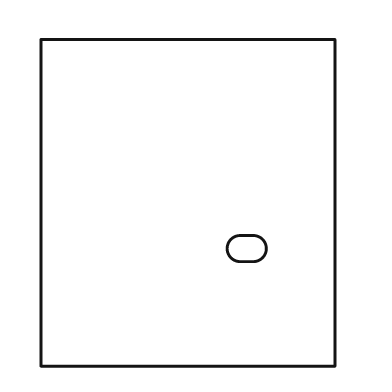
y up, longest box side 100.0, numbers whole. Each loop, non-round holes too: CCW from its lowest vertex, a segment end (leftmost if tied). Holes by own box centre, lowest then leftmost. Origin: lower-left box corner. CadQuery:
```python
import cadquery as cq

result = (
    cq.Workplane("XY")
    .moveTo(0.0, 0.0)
    .lineTo(90.0, 0.0)
    .lineTo(90.0, 100.0)
    .lineTo(0.0, 100.0)
    .close()
    .moveTo(61.0, 32.0)
    .lineTo(65.0, 32.0)
    .threePointArc((69.0, 36.0), (65.0, 40.0))
    .lineTo(61.0, 40.0)
    .threePointArc((57.0, 36.0), (61.0, 32.0))
    .close()
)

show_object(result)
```